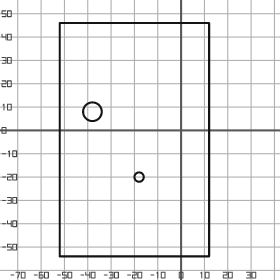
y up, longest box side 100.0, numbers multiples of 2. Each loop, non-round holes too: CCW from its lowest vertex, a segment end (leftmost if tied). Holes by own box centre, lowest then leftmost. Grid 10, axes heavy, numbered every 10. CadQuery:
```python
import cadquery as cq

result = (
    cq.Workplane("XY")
    .moveTo(-52.0, -54.0)
    .lineTo(12.0, -54.0)
    .lineTo(12.0, 46.0)
    .lineTo(-52.0, 46.0)
    .close()
    .moveTo(-18.0, -20.0)
    .circle(2.0)
    .moveTo(-38.0, 8.0)
    .circle(4.0)
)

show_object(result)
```